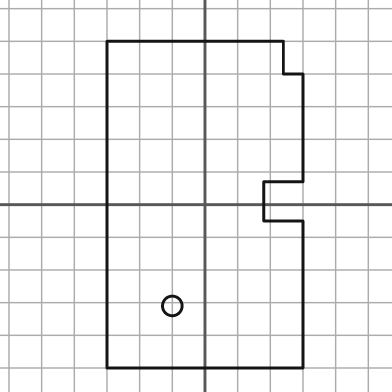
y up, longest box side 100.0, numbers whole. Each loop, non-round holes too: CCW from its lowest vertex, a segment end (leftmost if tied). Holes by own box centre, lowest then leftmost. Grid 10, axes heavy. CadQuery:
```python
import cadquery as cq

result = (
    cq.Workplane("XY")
    .moveTo(-30.0, -50.0)
    .lineTo(30.0, -50.0)
    .lineTo(30.0, -5.0)
    .lineTo(18.0, -5.0)
    .lineTo(18.0, 7.0)
    .lineTo(30.0, 7.0)
    .lineTo(30.0, 40.0)
    .lineTo(24.0, 40.0)
    .lineTo(24.0, 50.0)
    .lineTo(-30.0, 50.0)
    .close()
    .moveTo(-10.0, -31.0)
    .circle(3.0)
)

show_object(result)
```